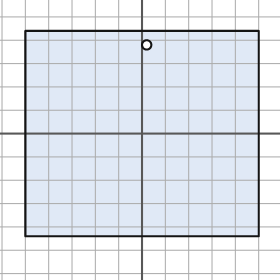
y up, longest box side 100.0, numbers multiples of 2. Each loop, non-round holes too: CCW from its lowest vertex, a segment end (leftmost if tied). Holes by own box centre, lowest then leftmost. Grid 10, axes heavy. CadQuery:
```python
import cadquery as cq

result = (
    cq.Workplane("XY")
    .moveTo(-50.0, -44.0)
    .lineTo(50.0, -44.0)
    .lineTo(50.0, 44.0)
    .lineTo(-50.0, 44.0)
    .close()
    .moveTo(2.0, 38.0)
    .circle(2.0)
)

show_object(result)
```